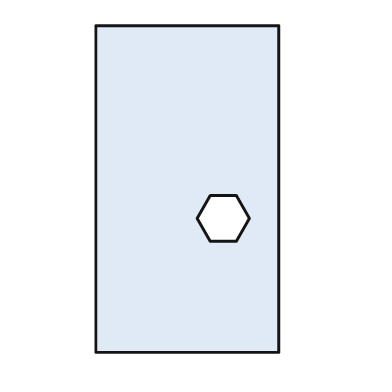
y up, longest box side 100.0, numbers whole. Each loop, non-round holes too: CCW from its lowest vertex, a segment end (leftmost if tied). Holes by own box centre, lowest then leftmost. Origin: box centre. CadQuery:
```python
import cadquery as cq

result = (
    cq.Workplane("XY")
    .moveTo(-28.0, -50.0)
    .lineTo(28.0, -50.0)
    .lineTo(28.0, 50.0)
    .lineTo(-28.0, 50.0)
    .close()
    .moveTo(7.0, -16.0)
    .lineTo(15.0, -16.0)
    .lineTo(19.0, -9.0)
    .lineTo(15.0, -2.0)
    .lineTo(7.0, -2.0)
    .lineTo(3.0, -9.0)
    .close()
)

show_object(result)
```